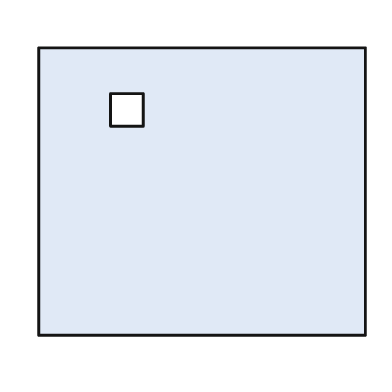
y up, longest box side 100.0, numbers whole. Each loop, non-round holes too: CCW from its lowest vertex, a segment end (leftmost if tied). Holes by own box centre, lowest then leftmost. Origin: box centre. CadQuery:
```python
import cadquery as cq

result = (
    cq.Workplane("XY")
    .moveTo(-50.0, -44.0)
    .lineTo(50.0, -44.0)
    .lineTo(50.0, 44.0)
    .lineTo(-50.0, 44.0)
    .close()
    .moveTo(-28.0, 20.0)
    .lineTo(-18.0, 20.0)
    .lineTo(-18.0, 30.0)
    .lineTo(-28.0, 30.0)
    .close()
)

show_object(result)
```